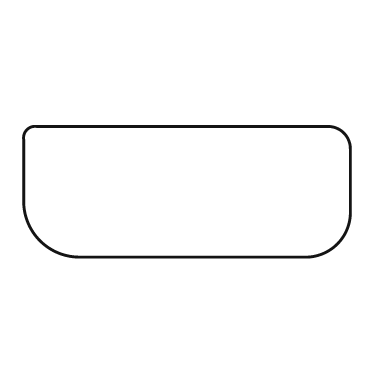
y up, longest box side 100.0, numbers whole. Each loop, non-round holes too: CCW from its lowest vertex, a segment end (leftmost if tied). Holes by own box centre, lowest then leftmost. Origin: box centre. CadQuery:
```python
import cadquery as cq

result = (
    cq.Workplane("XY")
    .moveTo(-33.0, -20.0)
    .lineTo(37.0, -20.0)
    .threePointArc((46.0, -16.0), (50.0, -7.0))
    .lineTo(50.0, 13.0)
    .threePointArc((48.0, 18.0), (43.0, 20.0))
    .lineTo(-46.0, 20.0)
    .threePointArc((-49.0, 19.0), (-50.0, 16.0))
    .lineTo(-50.0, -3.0)
    .threePointArc((-45.0, -15.0), (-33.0, -20.0))
    .close()
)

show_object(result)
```